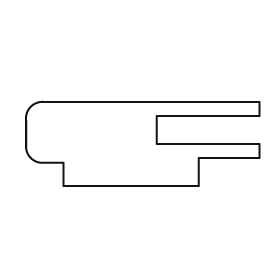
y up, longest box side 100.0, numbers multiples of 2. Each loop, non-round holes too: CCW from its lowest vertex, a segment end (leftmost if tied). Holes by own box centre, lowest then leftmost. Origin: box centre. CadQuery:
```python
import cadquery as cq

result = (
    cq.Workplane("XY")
    .moveTo(-34.0, -18.0)
    .lineTo(24.0, -18.0)
    .lineTo(24.0, -6.0)
    .lineTo(50.0, -6.0)
    .lineTo(50.0, 0.0)
    .lineTo(6.0, 0.0)
    .lineTo(6.0, 12.0)
    .lineTo(50.0, 12.0)
    .lineTo(50.0, 18.0)
    .lineTo(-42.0, 18.0)
    .threePointArc((-48.0, 16.0), (-50.0, 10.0))
    .lineTo(-50.0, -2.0)
    .threePointArc((-48.0, -6.0), (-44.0, -8.0))
    .lineTo(-34.0, -8.0)
    .close()
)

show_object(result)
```